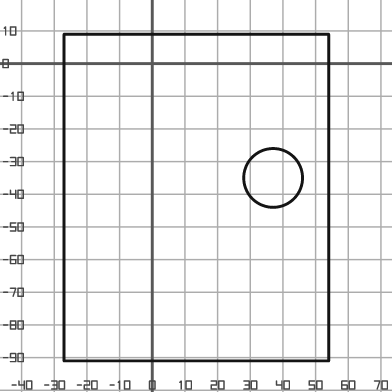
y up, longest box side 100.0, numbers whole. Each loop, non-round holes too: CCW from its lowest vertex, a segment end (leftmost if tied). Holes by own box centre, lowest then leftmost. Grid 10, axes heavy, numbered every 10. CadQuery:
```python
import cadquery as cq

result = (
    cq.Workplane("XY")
    .moveTo(-27.0, -91.0)
    .lineTo(54.0, -91.0)
    .lineTo(54.0, 9.0)
    .lineTo(-27.0, 9.0)
    .close()
    .moveTo(37.0, -35.0)
    .circle(9.0)
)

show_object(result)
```